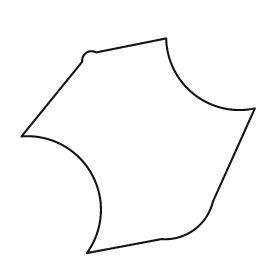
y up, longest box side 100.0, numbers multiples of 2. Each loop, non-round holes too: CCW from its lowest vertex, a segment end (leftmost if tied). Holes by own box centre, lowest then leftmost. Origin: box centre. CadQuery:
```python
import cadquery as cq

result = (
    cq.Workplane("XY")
    .moveTo(-22.0, -46.0)
    .lineTo(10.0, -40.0)
    .threePointArc((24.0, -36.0), (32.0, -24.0))
    .lineTo(50.0, 16.0)
    .threePointArc((24.0, 22.0), (12.0, 46.0))
    .lineTo(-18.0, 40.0)
    .threePointArc((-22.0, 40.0), (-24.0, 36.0))
    .lineTo(-50.0, 4.0)
    .threePointArc((-20.0, -12.0), (-22.0, -46.0))
    .close()
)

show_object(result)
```